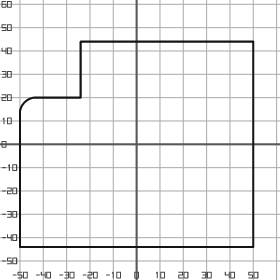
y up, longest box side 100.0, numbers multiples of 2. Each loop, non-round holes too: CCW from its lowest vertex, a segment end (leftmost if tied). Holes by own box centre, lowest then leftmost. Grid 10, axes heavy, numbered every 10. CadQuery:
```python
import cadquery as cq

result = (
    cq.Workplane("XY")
    .moveTo(-50.0, -44.0)
    .lineTo(50.0, -44.0)
    .lineTo(50.0, 44.0)
    .lineTo(-24.0, 44.0)
    .lineTo(-24.0, 20.0)
    .lineTo(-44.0, 20.0)
    .threePointArc((-48.0, 18.0), (-50.0, 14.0))
    .close()
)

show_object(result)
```